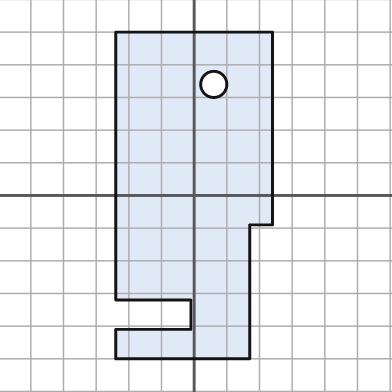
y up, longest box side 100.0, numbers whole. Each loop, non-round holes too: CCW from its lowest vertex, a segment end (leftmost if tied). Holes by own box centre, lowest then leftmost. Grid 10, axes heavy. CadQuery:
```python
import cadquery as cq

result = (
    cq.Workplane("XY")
    .moveTo(-24.0, -50.0)
    .lineTo(17.0, -50.0)
    .lineTo(17.0, -9.0)
    .lineTo(24.0, -9.0)
    .lineTo(24.0, 50.0)
    .lineTo(-24.0, 50.0)
    .lineTo(-24.0, -32.0)
    .lineTo(-1.0, -32.0)
    .lineTo(-1.0, -41.0)
    .lineTo(-24.0, -41.0)
    .close()
    .moveTo(6.0, 34.0)
    .circle(4.0)
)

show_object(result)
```